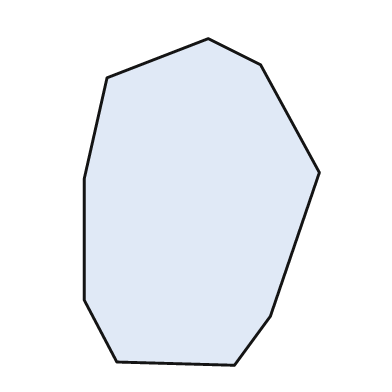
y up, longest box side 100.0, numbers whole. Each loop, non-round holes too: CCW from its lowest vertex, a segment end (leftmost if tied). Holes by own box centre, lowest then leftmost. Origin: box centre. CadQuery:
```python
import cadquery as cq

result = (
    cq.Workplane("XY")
    .moveTo(10.0, -50.0)
    .lineTo(21.0, -35.0)
    .lineTo(36.0, 9.0)
    .lineTo(18.0, 42.0)
    .lineTo(2.0, 50.0)
    .lineTo(-29.0, 38.0)
    .lineTo(-36.0, 7.0)
    .lineTo(-36.0, -30.0)
    .lineTo(-26.0, -49.0)
    .close()
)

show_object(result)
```